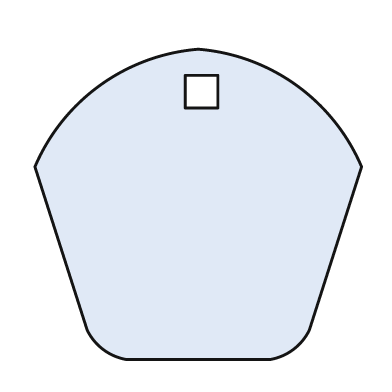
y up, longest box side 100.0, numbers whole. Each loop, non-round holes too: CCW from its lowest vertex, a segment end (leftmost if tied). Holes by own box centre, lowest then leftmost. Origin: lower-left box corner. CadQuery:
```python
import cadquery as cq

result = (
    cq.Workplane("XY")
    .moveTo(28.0, 0.0)
    .lineTo(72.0, 0.0)
    .threePointArc((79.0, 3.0), (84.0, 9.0))
    .lineTo(100.0, 59.0)
    .threePointArc((80.0, 84.0), (50.0, 95.0))
    .threePointArc((20.0, 84.0), (0.0, 59.0))
    .lineTo(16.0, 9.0)
    .threePointArc((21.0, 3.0), (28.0, 0.0))
    .close()
    .moveTo(46.0, 77.0)
    .lineTo(56.0, 77.0)
    .lineTo(56.0, 87.0)
    .lineTo(46.0, 87.0)
    .close()
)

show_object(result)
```